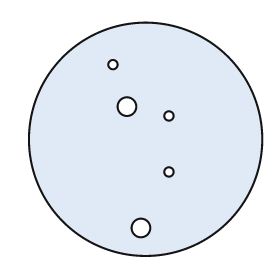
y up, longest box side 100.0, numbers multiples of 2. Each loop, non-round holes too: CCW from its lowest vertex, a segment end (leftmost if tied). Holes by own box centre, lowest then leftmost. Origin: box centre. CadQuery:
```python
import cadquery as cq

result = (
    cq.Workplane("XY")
    .moveTo(0.0, 0.0)
    .circle(50.0)
    .moveTo(-2.0, -38.0)
    .circle(4.0)
    .moveTo(10.0, -14.0)
    .circle(2.0)
    .moveTo(10.0, 10.0)
    .circle(2.0)
    .moveTo(-8.0, 14.0)
    .circle(4.0)
    .moveTo(-14.0, 32.0)
    .circle(2.0)
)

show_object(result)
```